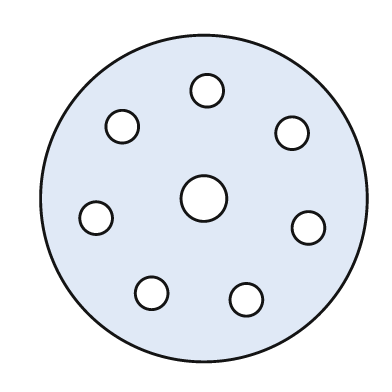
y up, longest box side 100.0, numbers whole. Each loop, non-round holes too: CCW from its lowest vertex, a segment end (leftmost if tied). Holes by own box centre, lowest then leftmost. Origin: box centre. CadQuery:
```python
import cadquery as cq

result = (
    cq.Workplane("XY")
    .moveTo(0.0, 0.0)
    .circle(50.0)
    .moveTo(13.0, -31.0)
    .circle(5.0)
    .moveTo(-16.0, -29.0)
    .circle(5.0)
    .moveTo(32.0, -9.0)
    .circle(5.0)
    .moveTo(-33.0, -6.0)
    .circle(5.0)
    .moveTo(0.0, 0.0)
    .circle(7.0)
    .moveTo(27.0, 20.0)
    .circle(5.0)
    .moveTo(-25.0, 22.0)
    .circle(5.0)
    .moveTo(1.0, 33.0)
    .circle(5.0)
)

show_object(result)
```